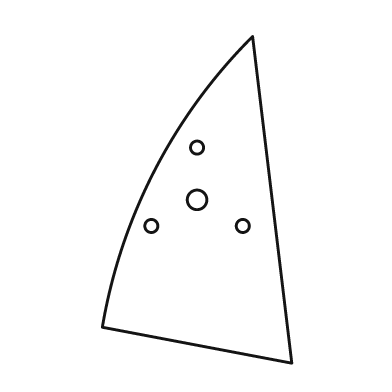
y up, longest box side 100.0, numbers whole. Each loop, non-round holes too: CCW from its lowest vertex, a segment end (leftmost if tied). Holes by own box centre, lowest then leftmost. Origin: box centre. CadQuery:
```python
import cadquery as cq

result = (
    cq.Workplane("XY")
    .moveTo(29.0, -50.0)
    .lineTo(17.0, 50.0)
    .threePointArc((-13.0, 9.0), (-29.0, -39.0))
    .close()
    .moveTo(-14.0, -8.0)
    .circle(2.0)
    .moveTo(14.0, -8.0)
    .circle(2.0)
    .moveTo(0.0, 0.0)
    .circle(3.0)
    .moveTo(0.0, 16.0)
    .circle(2.0)
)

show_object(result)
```